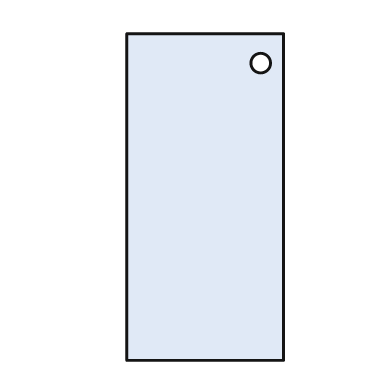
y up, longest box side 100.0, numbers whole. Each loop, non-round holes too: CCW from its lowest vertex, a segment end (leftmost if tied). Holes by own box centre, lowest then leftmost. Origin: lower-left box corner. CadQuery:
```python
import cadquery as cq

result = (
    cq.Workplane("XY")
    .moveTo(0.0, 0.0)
    .lineTo(48.0, 0.0)
    .lineTo(48.0, 100.0)
    .lineTo(0.0, 100.0)
    .close()
    .moveTo(41.0, 91.0)
    .circle(3.0)
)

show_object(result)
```